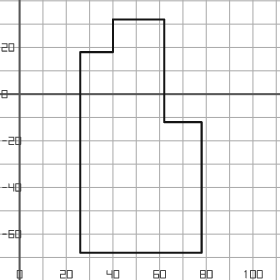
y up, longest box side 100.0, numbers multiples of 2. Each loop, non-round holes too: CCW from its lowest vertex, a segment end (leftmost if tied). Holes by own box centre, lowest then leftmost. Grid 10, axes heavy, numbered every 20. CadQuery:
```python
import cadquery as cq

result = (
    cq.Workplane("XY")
    .moveTo(26.0, -68.0)
    .lineTo(78.0, -68.0)
    .lineTo(78.0, -12.0)
    .lineTo(62.0, -12.0)
    .lineTo(62.0, 32.0)
    .lineTo(40.0, 32.0)
    .lineTo(40.0, 18.0)
    .lineTo(26.0, 18.0)
    .close()
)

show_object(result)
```